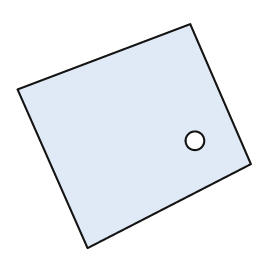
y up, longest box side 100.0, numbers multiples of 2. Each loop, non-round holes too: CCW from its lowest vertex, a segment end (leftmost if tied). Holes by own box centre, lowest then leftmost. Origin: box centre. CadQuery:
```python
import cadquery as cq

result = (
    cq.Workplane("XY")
    .moveTo(-20.0, -48.0)
    .lineTo(50.0, -12.0)
    .lineTo(24.0, 48.0)
    .lineTo(-50.0, 20.0)
    .close()
    .moveTo(26.0, -2.0)
    .circle(4.0)
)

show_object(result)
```